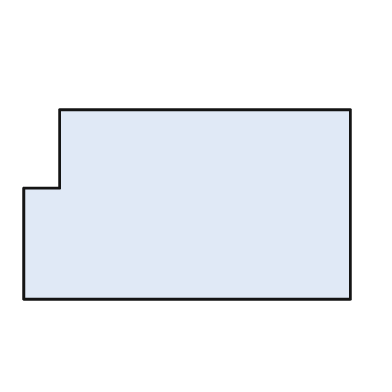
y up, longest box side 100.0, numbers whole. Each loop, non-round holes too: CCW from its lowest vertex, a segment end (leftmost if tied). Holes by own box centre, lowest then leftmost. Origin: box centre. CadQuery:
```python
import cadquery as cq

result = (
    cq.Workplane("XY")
    .moveTo(-50.0, -29.0)
    .lineTo(50.0, -29.0)
    .lineTo(50.0, 29.0)
    .lineTo(-39.0, 29.0)
    .lineTo(-39.0, 5.0)
    .lineTo(-50.0, 5.0)
    .close()
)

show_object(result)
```